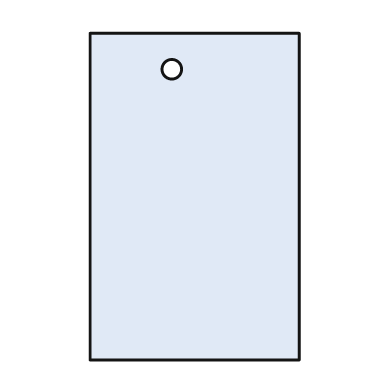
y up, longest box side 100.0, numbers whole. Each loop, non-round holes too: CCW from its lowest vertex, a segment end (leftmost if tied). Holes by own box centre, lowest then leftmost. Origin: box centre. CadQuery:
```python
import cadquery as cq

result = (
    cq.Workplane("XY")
    .moveTo(-32.0, -50.0)
    .lineTo(32.0, -50.0)
    .lineTo(32.0, 50.0)
    .lineTo(-32.0, 50.0)
    .close()
    .moveTo(-7.0, 39.0)
    .circle(3.0)
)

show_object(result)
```